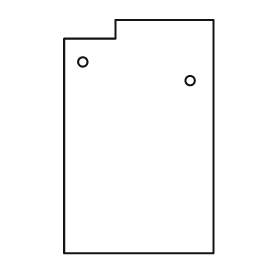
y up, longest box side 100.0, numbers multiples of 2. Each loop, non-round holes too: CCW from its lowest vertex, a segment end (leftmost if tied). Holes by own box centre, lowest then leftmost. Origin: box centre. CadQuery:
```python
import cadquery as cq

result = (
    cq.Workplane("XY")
    .moveTo(-32.0, -50.0)
    .lineTo(32.0, -50.0)
    .lineTo(32.0, 50.0)
    .lineTo(-10.0, 50.0)
    .lineTo(-10.0, 42.0)
    .lineTo(-32.0, 42.0)
    .close()
    .moveTo(22.0, 24.0)
    .circle(2.0)
    .moveTo(-24.0, 32.0)
    .circle(2.0)
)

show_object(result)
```